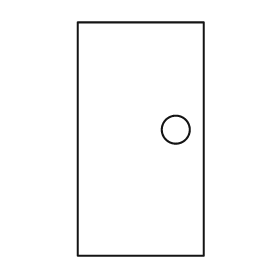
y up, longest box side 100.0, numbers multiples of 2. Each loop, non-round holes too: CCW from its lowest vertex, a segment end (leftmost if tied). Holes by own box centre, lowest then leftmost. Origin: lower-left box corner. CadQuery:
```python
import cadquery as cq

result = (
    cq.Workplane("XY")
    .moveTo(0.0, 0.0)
    .lineTo(54.0, 0.0)
    .lineTo(54.0, 100.0)
    .lineTo(0.0, 100.0)
    .close()
    .moveTo(42.0, 54.0)
    .circle(6.0)
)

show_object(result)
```